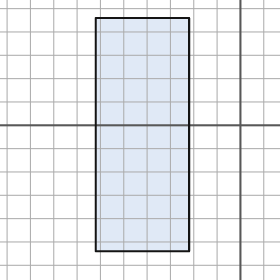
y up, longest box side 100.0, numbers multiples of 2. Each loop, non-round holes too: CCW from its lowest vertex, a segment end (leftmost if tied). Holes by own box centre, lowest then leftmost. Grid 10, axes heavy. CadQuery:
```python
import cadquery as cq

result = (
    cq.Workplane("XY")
    .moveTo(-62.0, -54.0)
    .lineTo(-22.0, -54.0)
    .lineTo(-22.0, 46.0)
    .lineTo(-62.0, 46.0)
    .close()
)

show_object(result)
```